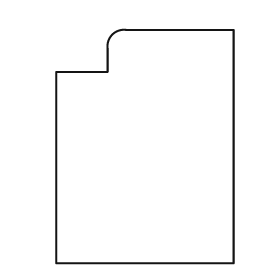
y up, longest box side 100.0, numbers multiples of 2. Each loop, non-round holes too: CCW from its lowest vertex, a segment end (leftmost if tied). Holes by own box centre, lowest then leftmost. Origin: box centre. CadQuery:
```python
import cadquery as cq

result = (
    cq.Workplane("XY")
    .moveTo(-38.0, -50.0)
    .lineTo(38.0, -50.0)
    .lineTo(38.0, 50.0)
    .lineTo(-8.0, 50.0)
    .threePointArc((-14.0, 48.0), (-16.0, 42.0))
    .lineTo(-16.0, 32.0)
    .lineTo(-38.0, 32.0)
    .close()
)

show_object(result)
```